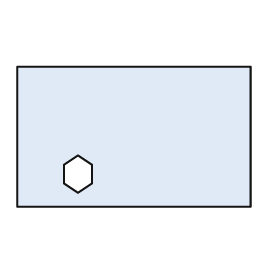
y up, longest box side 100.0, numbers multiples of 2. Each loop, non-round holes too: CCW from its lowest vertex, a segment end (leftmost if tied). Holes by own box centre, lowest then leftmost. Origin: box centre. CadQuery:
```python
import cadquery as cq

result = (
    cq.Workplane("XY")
    .moveTo(-50.0, -30.0)
    .lineTo(50.0, -30.0)
    .lineTo(50.0, 30.0)
    .lineTo(-50.0, 30.0)
    .close()
    .moveTo(-24.0, -24.0)
    .lineTo(-18.0, -20.0)
    .lineTo(-18.0, -12.0)
    .lineTo(-24.0, -8.0)
    .lineTo(-30.0, -12.0)
    .lineTo(-30.0, -20.0)
    .close()
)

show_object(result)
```